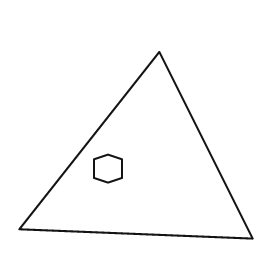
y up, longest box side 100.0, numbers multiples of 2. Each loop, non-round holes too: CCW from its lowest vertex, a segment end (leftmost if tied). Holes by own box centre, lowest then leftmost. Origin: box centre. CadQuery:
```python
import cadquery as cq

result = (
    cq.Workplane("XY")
    .moveTo(50.0, -40.0)
    .lineTo(10.0, 40.0)
    .lineTo(-50.0, -36.0)
    .close()
    .moveTo(-12.0, -16.0)
    .lineTo(-6.0, -14.0)
    .lineTo(-6.0, -6.0)
    .lineTo(-12.0, -4.0)
    .lineTo(-18.0, -6.0)
    .lineTo(-18.0, -14.0)
    .close()
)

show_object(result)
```